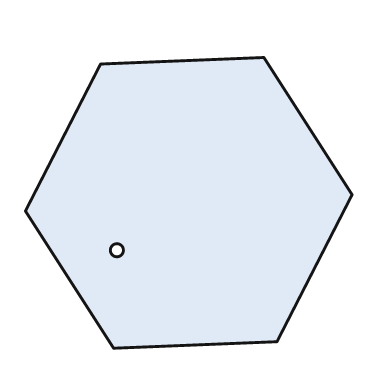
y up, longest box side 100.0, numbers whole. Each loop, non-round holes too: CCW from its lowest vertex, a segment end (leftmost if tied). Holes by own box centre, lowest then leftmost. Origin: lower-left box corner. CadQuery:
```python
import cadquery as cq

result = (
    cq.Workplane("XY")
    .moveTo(27.0, 0.0)
    .lineTo(77.0, 2.0)
    .lineTo(100.0, 47.0)
    .lineTo(73.0, 89.0)
    .lineTo(23.0, 87.0)
    .lineTo(0.0, 42.0)
    .close()
    .moveTo(28.0, 30.0)
    .circle(2.0)
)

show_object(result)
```